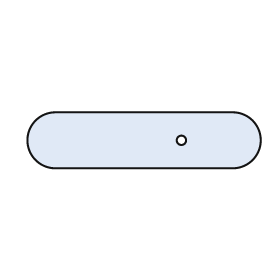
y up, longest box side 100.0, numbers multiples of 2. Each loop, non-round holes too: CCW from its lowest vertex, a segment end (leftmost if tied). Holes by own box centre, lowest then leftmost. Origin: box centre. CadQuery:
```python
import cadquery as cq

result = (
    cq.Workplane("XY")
    .moveTo(-38.0, -12.0)
    .lineTo(38.0, -12.0)
    .threePointArc((50.0, 0.0), (38.0, 12.0))
    .lineTo(-38.0, 12.0)
    .threePointArc((-50.0, 0.0), (-38.0, -12.0))
    .close()
    .moveTo(16.0, 0.0)
    .circle(2.0)
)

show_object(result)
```